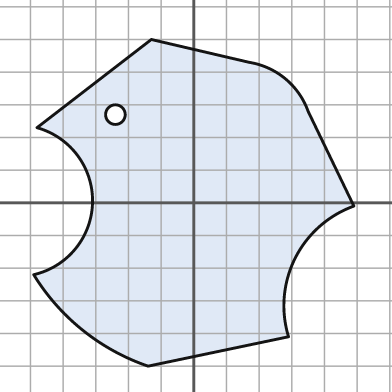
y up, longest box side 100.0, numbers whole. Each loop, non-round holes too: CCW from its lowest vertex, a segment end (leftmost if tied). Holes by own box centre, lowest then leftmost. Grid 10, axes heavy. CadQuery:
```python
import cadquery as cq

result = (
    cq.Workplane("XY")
    .moveTo(-14.0, -50.0)
    .lineTo(29.0, -41.0)
    .threePointArc((31.0, -17.0), (49.0, -1.0))
    .lineTo(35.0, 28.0)
    .threePointArc((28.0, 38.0), (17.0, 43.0))
    .lineTo(-13.0, 50.0)
    .lineTo(-48.0, 23.0)
    .threePointArc((-31.0, 0.0), (-49.0, -22.0))
    .threePointArc((-34.0, -39.0), (-14.0, -50.0))
    .close()
    .moveTo(-24.0, 27.0)
    .circle(3.0)
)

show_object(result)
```